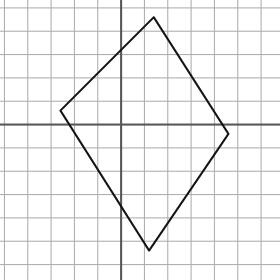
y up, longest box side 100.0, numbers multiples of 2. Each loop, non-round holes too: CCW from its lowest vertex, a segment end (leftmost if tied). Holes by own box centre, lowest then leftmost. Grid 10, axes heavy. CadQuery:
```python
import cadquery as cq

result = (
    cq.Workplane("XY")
    .moveTo(12.0, -54.0)
    .lineTo(46.0, -4.0)
    .lineTo(14.0, 46.0)
    .lineTo(-26.0, 6.0)
    .close()
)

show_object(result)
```